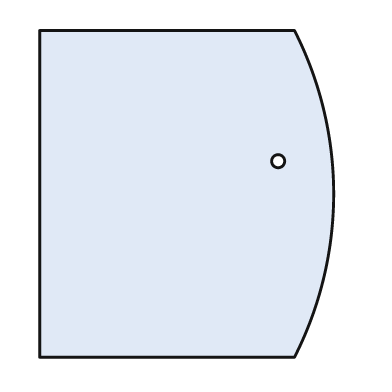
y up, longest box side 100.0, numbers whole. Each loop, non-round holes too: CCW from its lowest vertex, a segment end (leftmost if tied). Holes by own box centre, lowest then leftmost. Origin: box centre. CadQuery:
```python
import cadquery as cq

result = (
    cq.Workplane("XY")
    .moveTo(-45.0, -50.0)
    .lineTo(33.0, -50.0)
    .threePointArc((45.0, 0.0), (33.0, 50.0))
    .lineTo(-45.0, 50.0)
    .close()
    .moveTo(28.0, 10.0)
    .circle(2.0)
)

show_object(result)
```